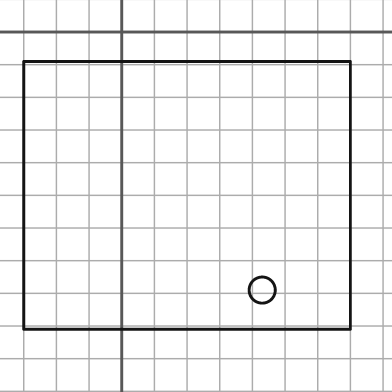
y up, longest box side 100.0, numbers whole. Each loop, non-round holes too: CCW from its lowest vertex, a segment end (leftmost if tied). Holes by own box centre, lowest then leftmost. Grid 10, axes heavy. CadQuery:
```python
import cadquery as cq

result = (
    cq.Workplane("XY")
    .moveTo(-30.0, -91.0)
    .lineTo(70.0, -91.0)
    .lineTo(70.0, -9.0)
    .lineTo(-30.0, -9.0)
    .close()
    .moveTo(43.0, -79.0)
    .circle(4.0)
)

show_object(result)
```